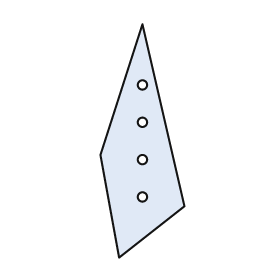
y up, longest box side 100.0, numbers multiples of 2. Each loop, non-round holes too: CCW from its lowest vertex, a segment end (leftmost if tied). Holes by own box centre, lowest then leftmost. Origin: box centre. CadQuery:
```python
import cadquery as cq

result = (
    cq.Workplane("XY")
    .moveTo(-10.0, -50.0)
    .lineTo(18.0, -28.0)
    .lineTo(0.0, 50.0)
    .lineTo(-18.0, -6.0)
    .close()
    .moveTo(0.0, -24.0)
    .circle(2.0)
    .moveTo(0.0, -8.0)
    .circle(2.0)
    .moveTo(0.0, 8.0)
    .circle(2.0)
    .moveTo(0.0, 24.0)
    .circle(2.0)
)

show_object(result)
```